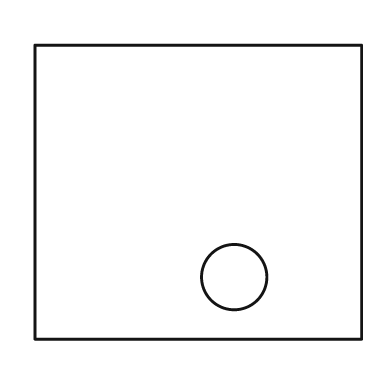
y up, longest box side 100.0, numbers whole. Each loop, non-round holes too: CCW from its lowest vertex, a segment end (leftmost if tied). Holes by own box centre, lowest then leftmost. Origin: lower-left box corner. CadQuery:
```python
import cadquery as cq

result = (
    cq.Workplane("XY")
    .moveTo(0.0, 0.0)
    .lineTo(100.0, 0.0)
    .lineTo(100.0, 90.0)
    .lineTo(0.0, 90.0)
    .close()
    .moveTo(61.0, 19.0)
    .circle(10.0)
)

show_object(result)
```